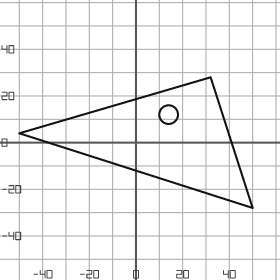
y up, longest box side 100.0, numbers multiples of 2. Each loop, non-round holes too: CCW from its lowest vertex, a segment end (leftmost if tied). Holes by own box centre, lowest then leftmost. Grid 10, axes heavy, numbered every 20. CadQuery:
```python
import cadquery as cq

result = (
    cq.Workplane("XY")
    .moveTo(50.0, -28.0)
    .lineTo(32.0, 28.0)
    .lineTo(-50.0, 4.0)
    .close()
    .moveTo(14.0, 12.0)
    .circle(4.0)
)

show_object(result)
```